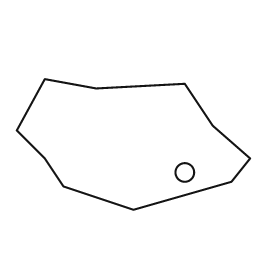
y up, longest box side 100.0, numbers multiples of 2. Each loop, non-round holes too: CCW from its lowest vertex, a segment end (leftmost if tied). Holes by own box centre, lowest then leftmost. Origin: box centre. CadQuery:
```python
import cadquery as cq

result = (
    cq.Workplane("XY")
    .moveTo(0.0, -28.0)
    .lineTo(42.0, -16.0)
    .lineTo(50.0, -6.0)
    .lineTo(34.0, 8.0)
    .lineTo(22.0, 26.0)
    .lineTo(-16.0, 24.0)
    .lineTo(-38.0, 28.0)
    .lineTo(-50.0, 6.0)
    .lineTo(-38.0, -6.0)
    .lineTo(-30.0, -18.0)
    .close()
    .moveTo(22.0, -12.0)
    .circle(4.0)
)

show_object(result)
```